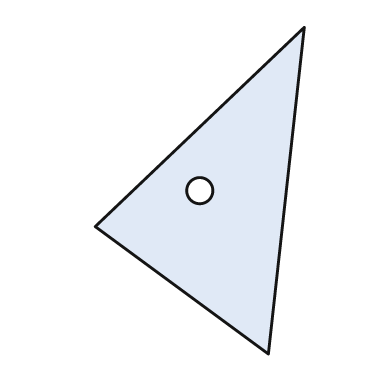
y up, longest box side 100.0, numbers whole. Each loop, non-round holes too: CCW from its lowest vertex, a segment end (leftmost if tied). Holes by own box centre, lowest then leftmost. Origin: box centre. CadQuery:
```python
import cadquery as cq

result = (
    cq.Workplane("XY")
    .moveTo(21.0, -50.0)
    .lineTo(32.0, 50.0)
    .lineTo(-32.0, -11.0)
    .close()
    .moveTo(0.0, 0.0)
    .circle(4.0)
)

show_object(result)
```